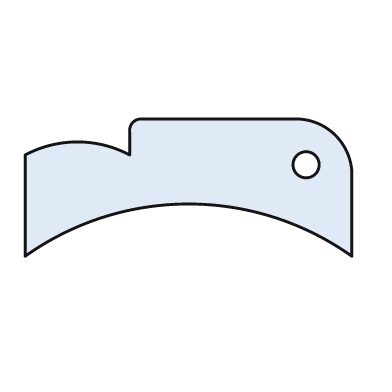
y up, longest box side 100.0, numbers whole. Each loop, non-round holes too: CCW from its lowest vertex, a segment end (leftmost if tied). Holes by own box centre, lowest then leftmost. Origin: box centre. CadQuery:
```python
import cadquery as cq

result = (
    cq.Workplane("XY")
    .moveTo(-50.0, -21.0)
    .threePointArc((0.0, -5.0), (50.0, -21.0))
    .lineTo(50.0, 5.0)
    .threePointArc((45.0, 16.0), (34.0, 21.0))
    .lineTo(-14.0, 21.0)
    .threePointArc((-17.0, 20.0), (-18.0, 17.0))
    .lineTo(-18.0, 10.0)
    .threePointArc((-34.0, 14.0), (-50.0, 10.0))
    .close()
    .moveTo(36.0, 7.0)
    .circle(4.0)
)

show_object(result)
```